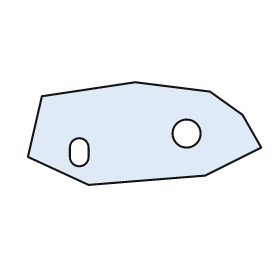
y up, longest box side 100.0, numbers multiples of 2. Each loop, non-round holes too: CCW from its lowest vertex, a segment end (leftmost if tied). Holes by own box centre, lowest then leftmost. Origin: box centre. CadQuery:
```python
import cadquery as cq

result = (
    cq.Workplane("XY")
    .moveTo(-24.0, -22.0)
    .lineTo(26.0, -18.0)
    .lineTo(50.0, -6.0)
    .lineTo(42.0, 8.0)
    .lineTo(28.0, 18.0)
    .lineTo(-4.0, 22.0)
    .lineTo(-44.0, 16.0)
    .lineTo(-50.0, -10.0)
    .close()
    .moveTo(-32.0, -10.0)
    .threePointArc((-28.0, -14.0), (-24.0, -10.0))
    .lineTo(-24.0, -6.0)
    .threePointArc((-28.0, -2.0), (-32.0, -6.0))
    .close()
    .moveTo(18.0, 0.0)
    .circle(6.0)
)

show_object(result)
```